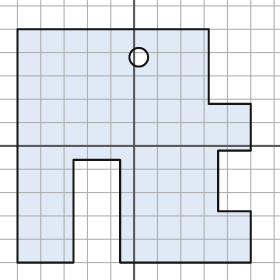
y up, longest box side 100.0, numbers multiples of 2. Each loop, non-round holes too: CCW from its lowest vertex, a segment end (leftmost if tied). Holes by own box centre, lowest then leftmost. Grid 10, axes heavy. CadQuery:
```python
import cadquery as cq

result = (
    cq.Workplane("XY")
    .moveTo(-50.0, -50.0)
    .lineTo(-26.0, -50.0)
    .lineTo(-26.0, -6.0)
    .lineTo(-6.0, -6.0)
    .lineTo(-6.0, -50.0)
    .lineTo(50.0, -50.0)
    .lineTo(50.0, -28.0)
    .lineTo(36.0, -28.0)
    .lineTo(36.0, -2.0)
    .lineTo(50.0, -2.0)
    .lineTo(50.0, 18.0)
    .lineTo(32.0, 18.0)
    .lineTo(32.0, 50.0)
    .lineTo(-50.0, 50.0)
    .close()
    .moveTo(2.0, 38.0)
    .circle(4.0)
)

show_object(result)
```